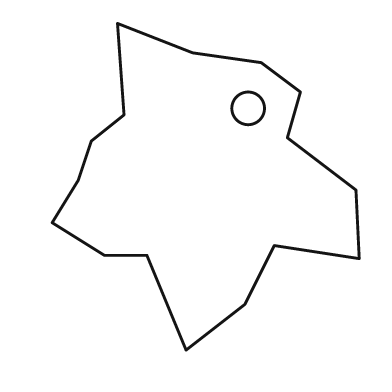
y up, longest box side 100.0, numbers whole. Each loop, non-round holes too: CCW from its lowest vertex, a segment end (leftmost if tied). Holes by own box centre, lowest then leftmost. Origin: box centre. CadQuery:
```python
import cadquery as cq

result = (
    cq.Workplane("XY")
    .moveTo(-6.0, -50.0)
    .lineTo(12.0, -36.0)
    .lineTo(21.0, -18.0)
    .lineTo(47.0, -22.0)
    .lineTo(46.0, -1.0)
    .lineTo(25.0, 15.0)
    .lineTo(29.0, 29.0)
    .lineTo(17.0, 38.0)
    .lineTo(-4.0, 41.0)
    .lineTo(-27.0, 50.0)
    .lineTo(-25.0, 22.0)
    .lineTo(-35.0, 14.0)
    .lineTo(-39.0, 2.0)
    .lineTo(-47.0, -11.0)
    .lineTo(-31.0, -21.0)
    .lineTo(-18.0, -21.0)
    .close()
    .moveTo(13.0, 24.0)
    .circle(5.0)
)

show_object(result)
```